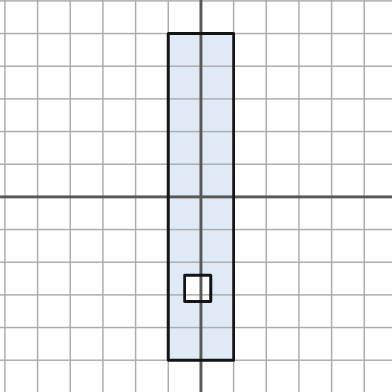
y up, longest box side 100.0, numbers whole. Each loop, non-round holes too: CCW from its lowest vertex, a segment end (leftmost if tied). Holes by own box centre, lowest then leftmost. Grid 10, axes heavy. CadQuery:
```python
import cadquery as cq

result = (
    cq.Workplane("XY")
    .moveTo(-10.0, -50.0)
    .lineTo(10.0, -50.0)
    .lineTo(10.0, 50.0)
    .lineTo(-10.0, 50.0)
    .close()
    .moveTo(-5.0, -32.0)
    .lineTo(3.0, -32.0)
    .lineTo(3.0, -24.0)
    .lineTo(-5.0, -24.0)
    .close()
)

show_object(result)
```